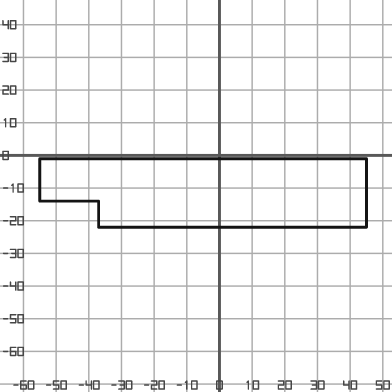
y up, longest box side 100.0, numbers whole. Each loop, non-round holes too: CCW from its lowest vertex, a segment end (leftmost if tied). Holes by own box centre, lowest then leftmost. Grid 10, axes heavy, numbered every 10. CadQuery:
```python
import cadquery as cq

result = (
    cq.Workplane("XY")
    .moveTo(-37.0, -22.0)
    .lineTo(45.0, -22.0)
    .lineTo(45.0, -1.0)
    .lineTo(-55.0, -1.0)
    .lineTo(-55.0, -14.0)
    .lineTo(-37.0, -14.0)
    .close()
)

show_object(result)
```